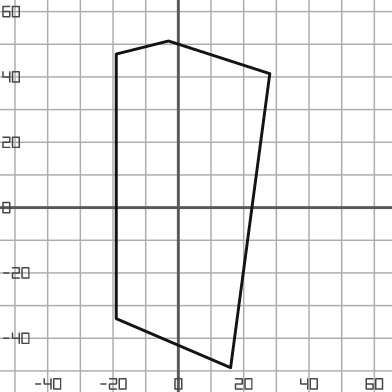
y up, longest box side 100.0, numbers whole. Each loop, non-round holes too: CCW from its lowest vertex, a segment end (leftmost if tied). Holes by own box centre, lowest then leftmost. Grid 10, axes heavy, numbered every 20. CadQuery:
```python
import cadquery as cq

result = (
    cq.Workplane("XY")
    .moveTo(16.0, -49.0)
    .lineTo(28.0, 41.0)
    .lineTo(-3.0, 51.0)
    .lineTo(-19.0, 47.0)
    .lineTo(-19.0, -34.0)
    .close()
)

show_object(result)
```